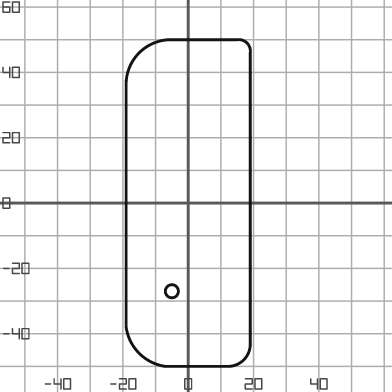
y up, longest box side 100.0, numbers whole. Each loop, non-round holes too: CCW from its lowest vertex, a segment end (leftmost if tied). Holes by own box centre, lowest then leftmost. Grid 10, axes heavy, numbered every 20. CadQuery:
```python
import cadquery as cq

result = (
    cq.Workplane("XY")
    .moveTo(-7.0, -50.0)
    .lineTo(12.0, -50.0)
    .threePointArc((17.0, -48.0), (19.0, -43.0))
    .lineTo(19.0, 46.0)
    .threePointArc((18.0, 49.0), (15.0, 50.0))
    .lineTo(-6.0, 50.0)
    .threePointArc((-15.0, 46.0), (-19.0, 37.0))
    .lineTo(-19.0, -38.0)
    .threePointArc((-15.0, -46.0), (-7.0, -50.0))
    .close()
    .moveTo(-5.0, -27.0)
    .circle(2.0)
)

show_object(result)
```